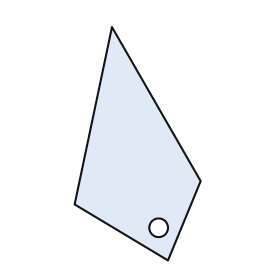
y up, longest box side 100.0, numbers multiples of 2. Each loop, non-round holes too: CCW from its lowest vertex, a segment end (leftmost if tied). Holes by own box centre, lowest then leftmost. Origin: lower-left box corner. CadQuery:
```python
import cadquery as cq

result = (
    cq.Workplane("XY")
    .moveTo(40.0, 0.0)
    .lineTo(54.0, 34.0)
    .lineTo(16.0, 100.0)
    .lineTo(0.0, 24.0)
    .close()
    .moveTo(36.0, 14.0)
    .circle(4.0)
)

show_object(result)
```